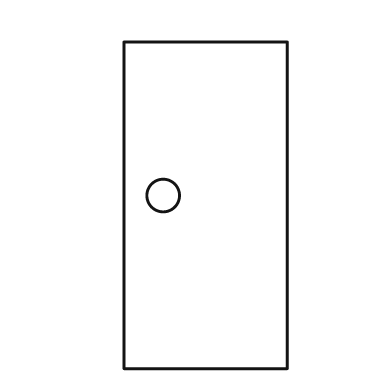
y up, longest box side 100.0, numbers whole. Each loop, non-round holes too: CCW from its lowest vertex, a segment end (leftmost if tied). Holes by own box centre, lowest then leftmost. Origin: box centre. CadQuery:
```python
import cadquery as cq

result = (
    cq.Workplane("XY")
    .moveTo(-25.0, -50.0)
    .lineTo(25.0, -50.0)
    .lineTo(25.0, 50.0)
    .lineTo(-25.0, 50.0)
    .close()
    .moveTo(-13.0, 3.0)
    .circle(5.0)
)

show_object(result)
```